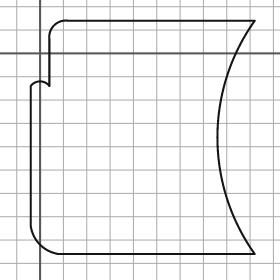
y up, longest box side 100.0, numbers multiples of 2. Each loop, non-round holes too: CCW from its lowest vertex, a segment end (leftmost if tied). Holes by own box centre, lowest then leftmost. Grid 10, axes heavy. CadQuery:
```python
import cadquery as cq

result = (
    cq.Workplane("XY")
    .moveTo(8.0, -86.0)
    .lineTo(92.0, -86.0)
    .threePointArc((76.0, -36.0), (92.0, 14.0))
    .lineTo(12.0, 14.0)
    .threePointArc((6.0, 12.0), (4.0, 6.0))
    .lineTo(4.0, -14.0)
    .threePointArc((0.0, -12.0), (-4.0, -14.0))
    .lineTo(-4.0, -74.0)
    .threePointArc((0.0, -82.0), (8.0, -86.0))
    .close()
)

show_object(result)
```